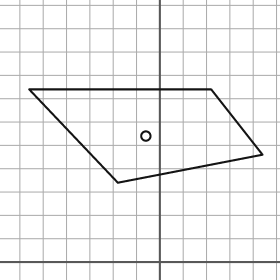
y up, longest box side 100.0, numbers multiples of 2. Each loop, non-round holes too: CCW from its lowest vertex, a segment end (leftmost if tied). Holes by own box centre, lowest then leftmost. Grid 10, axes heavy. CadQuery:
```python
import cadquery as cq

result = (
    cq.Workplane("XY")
    .moveTo(-18.0, 34.0)
    .lineTo(44.0, 46.0)
    .lineTo(22.0, 74.0)
    .lineTo(-56.0, 74.0)
    .close()
    .moveTo(-6.0, 54.0)
    .circle(2.0)
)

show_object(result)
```